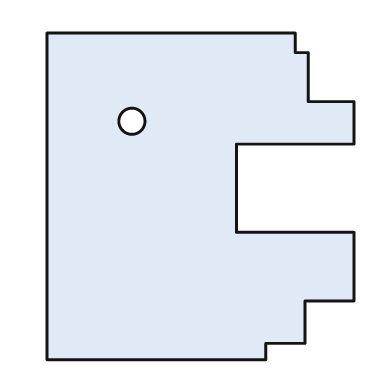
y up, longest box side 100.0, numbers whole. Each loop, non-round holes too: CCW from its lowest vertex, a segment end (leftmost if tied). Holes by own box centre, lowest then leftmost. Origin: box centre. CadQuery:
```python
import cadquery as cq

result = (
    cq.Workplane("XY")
    .moveTo(-47.0, -50.0)
    .lineTo(20.0, -50.0)
    .lineTo(20.0, -45.0)
    .lineTo(32.0, -45.0)
    .lineTo(32.0, -32.0)
    .lineTo(47.0, -32.0)
    .lineTo(47.0, -11.0)
    .lineTo(11.0, -11.0)
    .lineTo(11.0, 16.0)
    .lineTo(47.0, 16.0)
    .lineTo(47.0, 29.0)
    .lineTo(33.0, 29.0)
    .lineTo(33.0, 44.0)
    .lineTo(29.0, 44.0)
    .lineTo(29.0, 50.0)
    .lineTo(-47.0, 50.0)
    .close()
    .moveTo(-21.0, 23.0)
    .circle(4.0)
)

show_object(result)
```